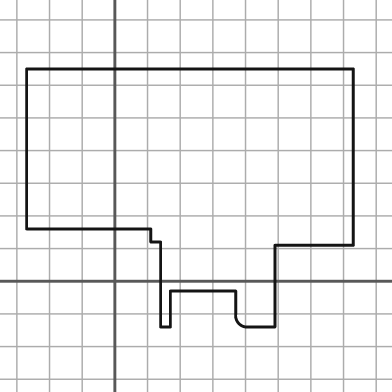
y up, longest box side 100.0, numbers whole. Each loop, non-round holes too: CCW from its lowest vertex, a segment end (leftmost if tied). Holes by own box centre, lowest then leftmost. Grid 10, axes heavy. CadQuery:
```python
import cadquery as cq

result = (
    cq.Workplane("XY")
    .moveTo(14.0, -14.0)
    .lineTo(17.0, -14.0)
    .lineTo(17.0, -3.0)
    .lineTo(37.0, -3.0)
    .lineTo(37.0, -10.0)
    .threePointArc((38.0, -13.0), (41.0, -14.0))
    .lineTo(49.0, -14.0)
    .lineTo(49.0, 11.0)
    .lineTo(73.0, 11.0)
    .lineTo(73.0, 65.0)
    .lineTo(-27.0, 65.0)
    .lineTo(-27.0, 16.0)
    .lineTo(11.0, 16.0)
    .lineTo(11.0, 12.0)
    .lineTo(14.0, 12.0)
    .close()
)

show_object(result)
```